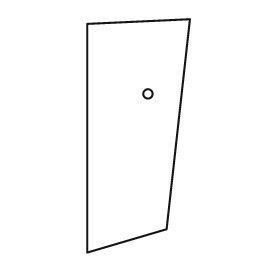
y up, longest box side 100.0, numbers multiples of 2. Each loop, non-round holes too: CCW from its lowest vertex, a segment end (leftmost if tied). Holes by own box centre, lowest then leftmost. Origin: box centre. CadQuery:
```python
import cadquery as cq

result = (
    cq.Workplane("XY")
    .moveTo(-22.0, -50.0)
    .lineTo(12.0, -40.0)
    .lineTo(22.0, 50.0)
    .lineTo(-22.0, 48.0)
    .close()
    .moveTo(4.0, 18.0)
    .circle(2.0)
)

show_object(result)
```